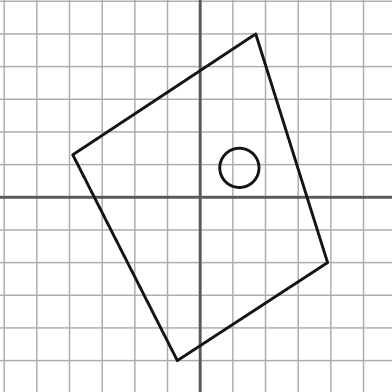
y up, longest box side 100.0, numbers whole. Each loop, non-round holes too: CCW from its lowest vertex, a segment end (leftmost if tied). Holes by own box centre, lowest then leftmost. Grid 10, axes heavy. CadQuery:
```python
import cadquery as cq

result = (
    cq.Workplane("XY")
    .moveTo(-7.0, -50.0)
    .lineTo(39.0, -20.0)
    .lineTo(17.0, 50.0)
    .lineTo(-39.0, 13.0)
    .close()
    .moveTo(12.0, 9.0)
    .circle(6.0)
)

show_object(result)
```